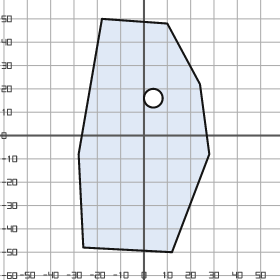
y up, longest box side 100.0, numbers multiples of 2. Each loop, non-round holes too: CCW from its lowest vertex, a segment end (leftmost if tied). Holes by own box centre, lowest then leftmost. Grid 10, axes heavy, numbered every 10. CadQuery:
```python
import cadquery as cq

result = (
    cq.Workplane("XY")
    .moveTo(12.0, -50.0)
    .lineTo(28.0, -8.0)
    .lineTo(24.0, 22.0)
    .lineTo(10.0, 48.0)
    .lineTo(-18.0, 50.0)
    .lineTo(-28.0, -8.0)
    .lineTo(-26.0, -48.0)
    .close()
    .moveTo(4.0, 16.0)
    .circle(4.0)
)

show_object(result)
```